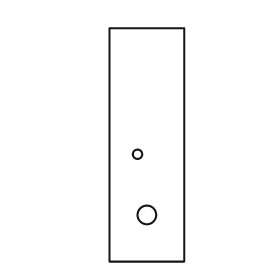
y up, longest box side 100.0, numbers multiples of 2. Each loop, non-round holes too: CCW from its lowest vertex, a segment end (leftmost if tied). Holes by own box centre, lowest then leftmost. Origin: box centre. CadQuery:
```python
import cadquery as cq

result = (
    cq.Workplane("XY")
    .moveTo(-16.0, -50.0)
    .lineTo(16.0, -50.0)
    .lineTo(16.0, 50.0)
    .lineTo(-16.0, 50.0)
    .close()
    .moveTo(0.0, -30.0)
    .circle(4.0)
    .moveTo(-4.0, -4.0)
    .circle(2.0)
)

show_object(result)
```